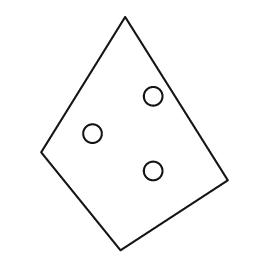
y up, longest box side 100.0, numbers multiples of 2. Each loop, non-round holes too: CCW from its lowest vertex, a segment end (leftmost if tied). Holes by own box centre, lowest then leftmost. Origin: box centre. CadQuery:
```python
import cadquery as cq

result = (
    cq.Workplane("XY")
    .moveTo(-6.0, -50.0)
    .lineTo(40.0, -20.0)
    .lineTo(-4.0, 50.0)
    .lineTo(-40.0, -8.0)
    .close()
    .moveTo(8.0, -16.0)
    .circle(4.0)
    .moveTo(-18.0, 0.0)
    .circle(4.0)
    .moveTo(8.0, 16.0)
    .circle(4.0)
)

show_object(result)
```